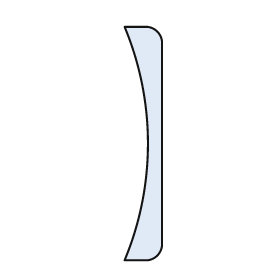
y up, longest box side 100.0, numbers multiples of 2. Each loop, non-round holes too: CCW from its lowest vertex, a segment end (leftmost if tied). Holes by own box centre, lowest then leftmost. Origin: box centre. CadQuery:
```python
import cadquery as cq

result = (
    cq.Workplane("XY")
    .moveTo(-8.0, -50.0)
    .lineTo(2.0, -50.0)
    .threePointArc((6.0, -48.0), (8.0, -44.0))
    .lineTo(8.0, 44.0)
    .threePointArc((6.0, 48.0), (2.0, 50.0))
    .lineTo(-8.0, 50.0)
    .threePointArc((2.0, 0.0), (-8.0, -50.0))
    .close()
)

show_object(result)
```